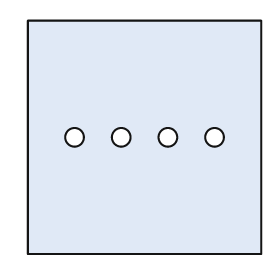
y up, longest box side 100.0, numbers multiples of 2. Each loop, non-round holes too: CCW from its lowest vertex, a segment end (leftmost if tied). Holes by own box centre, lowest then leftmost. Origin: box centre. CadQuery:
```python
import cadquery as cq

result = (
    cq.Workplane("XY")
    .moveTo(-50.0, -50.0)
    .lineTo(50.0, -50.0)
    .lineTo(50.0, 50.0)
    .lineTo(-50.0, 50.0)
    .close()
    .moveTo(-30.0, 0.0)
    .circle(4.0)
    .moveTo(-10.0, 0.0)
    .circle(4.0)
    .moveTo(10.0, 0.0)
    .circle(4.0)
    .moveTo(30.0, 0.0)
    .circle(4.0)
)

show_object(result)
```